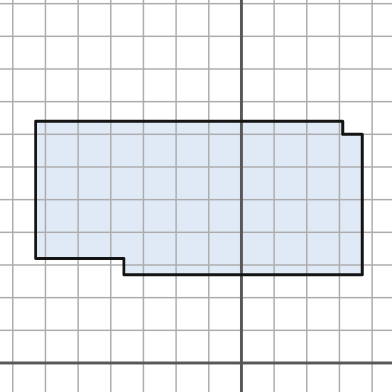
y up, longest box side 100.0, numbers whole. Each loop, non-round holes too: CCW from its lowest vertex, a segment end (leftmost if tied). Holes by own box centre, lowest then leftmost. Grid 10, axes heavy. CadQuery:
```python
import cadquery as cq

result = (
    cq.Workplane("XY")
    .moveTo(-36.0, 27.0)
    .lineTo(37.0, 27.0)
    .lineTo(37.0, 70.0)
    .lineTo(31.0, 70.0)
    .lineTo(31.0, 74.0)
    .lineTo(-63.0, 74.0)
    .lineTo(-63.0, 32.0)
    .lineTo(-36.0, 32.0)
    .close()
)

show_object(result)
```